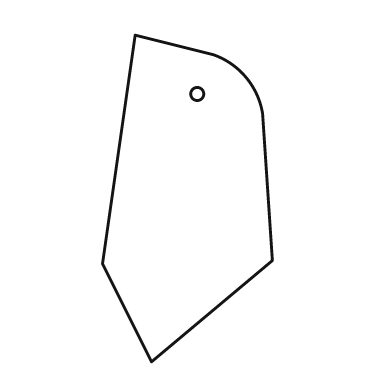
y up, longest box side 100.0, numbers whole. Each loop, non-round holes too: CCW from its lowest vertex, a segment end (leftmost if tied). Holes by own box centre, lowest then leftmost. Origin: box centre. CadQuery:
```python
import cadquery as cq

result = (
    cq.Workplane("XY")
    .moveTo(-11.0, -50.0)
    .lineTo(26.0, -19.0)
    .lineTo(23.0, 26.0)
    .threePointArc((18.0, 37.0), (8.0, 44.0))
    .lineTo(-16.0, 50.0)
    .lineTo(-26.0, -20.0)
    .close()
    .moveTo(3.0, 32.0)
    .circle(2.0)
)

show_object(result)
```